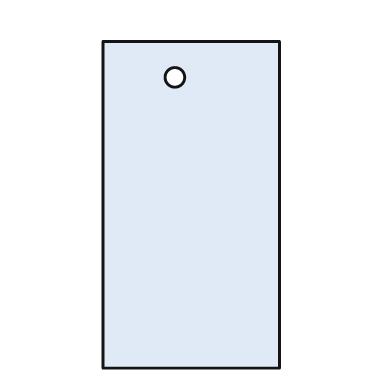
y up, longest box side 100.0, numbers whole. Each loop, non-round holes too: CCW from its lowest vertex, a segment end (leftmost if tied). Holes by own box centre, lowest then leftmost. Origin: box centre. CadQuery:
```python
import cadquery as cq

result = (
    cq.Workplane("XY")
    .moveTo(-27.0, -50.0)
    .lineTo(27.0, -50.0)
    .lineTo(27.0, 50.0)
    .lineTo(-27.0, 50.0)
    .close()
    .moveTo(-5.0, 39.0)
    .circle(3.0)
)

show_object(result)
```